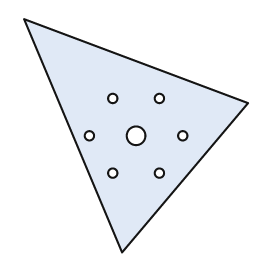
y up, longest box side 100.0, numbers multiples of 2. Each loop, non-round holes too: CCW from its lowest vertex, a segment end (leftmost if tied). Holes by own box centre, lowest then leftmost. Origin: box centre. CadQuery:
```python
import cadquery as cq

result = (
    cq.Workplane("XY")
    .moveTo(-6.0, -50.0)
    .lineTo(48.0, 14.0)
    .lineTo(-48.0, 50.0)
    .close()
    .moveTo(-10.0, -16.0)
    .circle(2.0)
    .moveTo(10.0, -16.0)
    .circle(2.0)
    .moveTo(-20.0, 0.0)
    .circle(2.0)
    .moveTo(0.0, 0.0)
    .circle(4.0)
    .moveTo(20.0, 0.0)
    .circle(2.0)
    .moveTo(-10.0, 16.0)
    .circle(2.0)
    .moveTo(10.0, 16.0)
    .circle(2.0)
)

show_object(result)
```